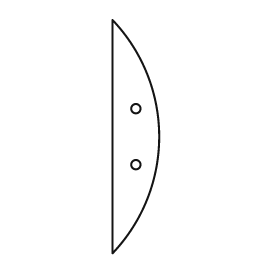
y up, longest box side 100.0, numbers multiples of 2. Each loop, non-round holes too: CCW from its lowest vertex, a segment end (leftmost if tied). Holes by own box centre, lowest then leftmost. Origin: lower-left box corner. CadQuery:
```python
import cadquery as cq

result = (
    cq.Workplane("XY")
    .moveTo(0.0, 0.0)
    .threePointArc((20.0, 50.0), (0.0, 100.0))
    .close()
    .moveTo(10.0, 38.0)
    .circle(2.0)
    .moveTo(10.0, 62.0)
    .circle(2.0)
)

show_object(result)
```